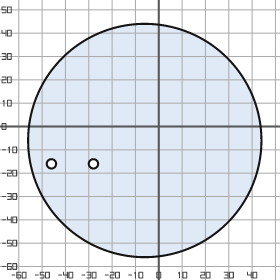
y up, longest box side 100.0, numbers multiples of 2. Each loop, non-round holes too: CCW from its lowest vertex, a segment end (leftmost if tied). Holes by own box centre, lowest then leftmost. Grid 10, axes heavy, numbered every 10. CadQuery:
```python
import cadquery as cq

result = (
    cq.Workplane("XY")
    .moveTo(-6.0, -6.0)
    .circle(50.0)
    .moveTo(-46.0, -16.0)
    .circle(2.0)
    .moveTo(-28.0, -16.0)
    .circle(2.0)
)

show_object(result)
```